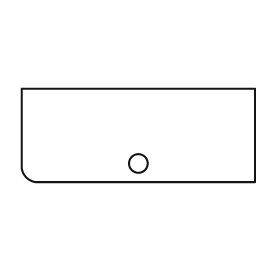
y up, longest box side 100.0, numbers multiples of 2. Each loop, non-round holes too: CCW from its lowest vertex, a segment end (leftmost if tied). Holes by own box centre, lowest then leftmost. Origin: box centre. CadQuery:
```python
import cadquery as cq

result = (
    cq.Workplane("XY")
    .moveTo(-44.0, -20.0)
    .lineTo(50.0, -20.0)
    .lineTo(50.0, 20.0)
    .lineTo(-50.0, 20.0)
    .lineTo(-50.0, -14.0)
    .threePointArc((-48.0, -18.0), (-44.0, -20.0))
    .close()
    .moveTo(0.0, -12.0)
    .circle(4.0)
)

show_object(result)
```